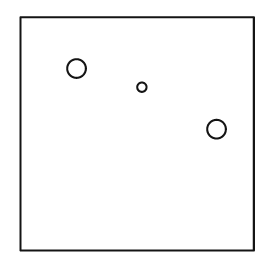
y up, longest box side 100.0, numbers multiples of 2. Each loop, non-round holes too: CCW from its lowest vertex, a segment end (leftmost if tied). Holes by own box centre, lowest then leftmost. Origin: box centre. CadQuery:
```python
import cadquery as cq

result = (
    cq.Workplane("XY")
    .moveTo(-50.0, -50.0)
    .lineTo(50.0, -50.0)
    .lineTo(50.0, 50.0)
    .lineTo(-50.0, 50.0)
    .close()
    .moveTo(34.0, 2.0)
    .circle(4.0)
    .moveTo(2.0, 20.0)
    .circle(2.0)
    .moveTo(-26.0, 28.0)
    .circle(4.0)
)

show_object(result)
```